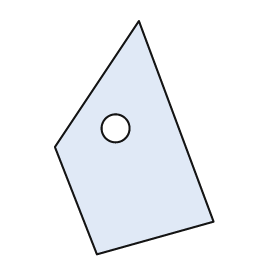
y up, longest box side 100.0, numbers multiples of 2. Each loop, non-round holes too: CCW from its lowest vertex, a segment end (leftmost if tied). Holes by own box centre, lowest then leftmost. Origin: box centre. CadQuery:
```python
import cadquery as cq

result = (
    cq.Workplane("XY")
    .moveTo(-16.0, -50.0)
    .lineTo(34.0, -36.0)
    .lineTo(2.0, 50.0)
    .lineTo(-34.0, -4.0)
    .close()
    .moveTo(-8.0, 4.0)
    .circle(6.0)
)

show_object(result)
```